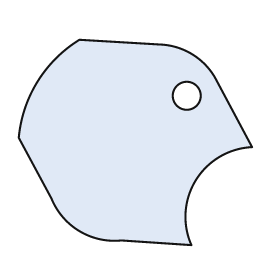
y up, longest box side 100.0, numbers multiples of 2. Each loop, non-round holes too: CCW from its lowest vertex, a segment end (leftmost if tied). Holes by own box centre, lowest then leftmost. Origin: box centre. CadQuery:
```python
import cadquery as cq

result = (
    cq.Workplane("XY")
    .moveTo(24.0, -44.0)
    .threePointArc((26.0, -16.0), (50.0, -2.0))
    .lineTo(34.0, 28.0)
    .threePointArc((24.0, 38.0), (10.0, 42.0))
    .lineTo(-24.0, 44.0)
    .threePointArc((-42.0, 26.0), (-50.0, 2.0))
    .lineTo(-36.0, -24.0)
    .threePointArc((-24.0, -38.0), (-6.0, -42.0))
    .close()
    .moveTo(22.0, 20.0)
    .circle(6.0)
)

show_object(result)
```